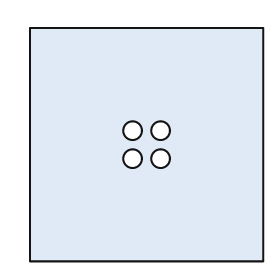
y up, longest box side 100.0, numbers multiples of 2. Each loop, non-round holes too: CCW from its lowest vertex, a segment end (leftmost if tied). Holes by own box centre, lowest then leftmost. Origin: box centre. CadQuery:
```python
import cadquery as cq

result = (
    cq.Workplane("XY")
    .moveTo(-50.0, -50.0)
    .lineTo(50.0, -50.0)
    .lineTo(50.0, 50.0)
    .lineTo(-50.0, 50.0)
    .close()
    .moveTo(-6.0, -6.0)
    .circle(4.0)
    .moveTo(6.0, -6.0)
    .circle(4.0)
    .moveTo(-6.0, 6.0)
    .circle(4.0)
    .moveTo(6.0, 6.0)
    .circle(4.0)
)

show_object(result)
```